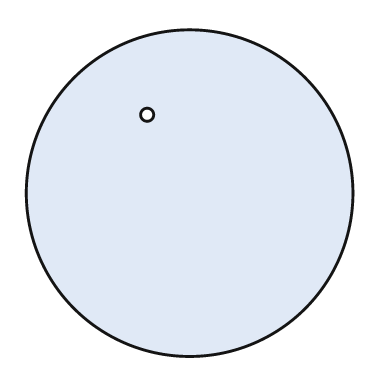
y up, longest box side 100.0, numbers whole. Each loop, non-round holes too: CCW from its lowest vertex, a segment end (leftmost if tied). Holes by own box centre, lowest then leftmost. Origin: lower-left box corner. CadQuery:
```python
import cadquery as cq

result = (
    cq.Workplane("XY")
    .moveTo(50.0, 50.0)
    .circle(50.0)
    .moveTo(37.0, 74.0)
    .circle(2.0)
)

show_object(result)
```